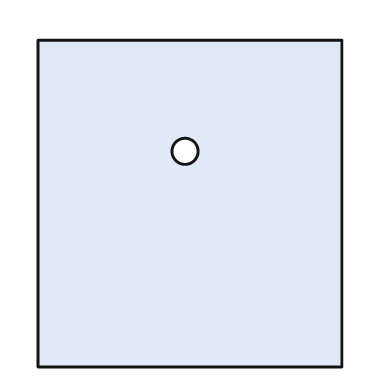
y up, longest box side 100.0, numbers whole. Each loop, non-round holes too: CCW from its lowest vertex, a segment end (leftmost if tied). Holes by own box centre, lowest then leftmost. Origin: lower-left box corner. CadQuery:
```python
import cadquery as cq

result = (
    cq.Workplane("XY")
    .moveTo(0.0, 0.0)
    .lineTo(93.0, 0.0)
    .lineTo(93.0, 100.0)
    .lineTo(0.0, 100.0)
    .close()
    .moveTo(45.0, 66.0)
    .circle(4.0)
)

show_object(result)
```